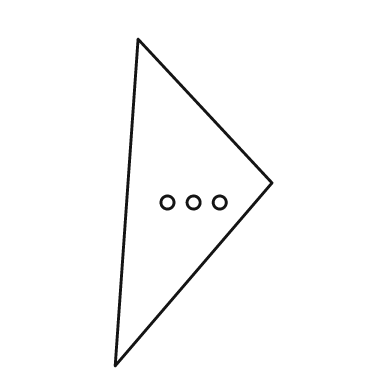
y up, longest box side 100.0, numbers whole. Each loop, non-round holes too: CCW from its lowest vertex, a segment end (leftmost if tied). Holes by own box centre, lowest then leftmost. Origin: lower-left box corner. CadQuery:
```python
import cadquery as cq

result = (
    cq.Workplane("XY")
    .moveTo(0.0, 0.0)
    .lineTo(48.0, 56.0)
    .lineTo(7.0, 100.0)
    .close()
    .moveTo(16.0, 50.0)
    .circle(2.0)
    .moveTo(24.0, 50.0)
    .circle(2.0)
    .moveTo(32.0, 50.0)
    .circle(2.0)
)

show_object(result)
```